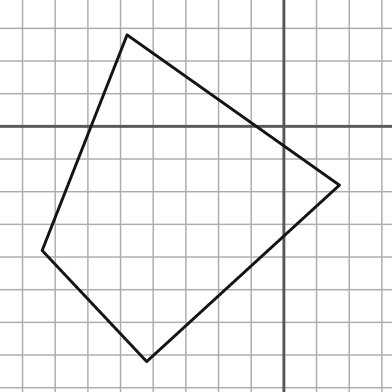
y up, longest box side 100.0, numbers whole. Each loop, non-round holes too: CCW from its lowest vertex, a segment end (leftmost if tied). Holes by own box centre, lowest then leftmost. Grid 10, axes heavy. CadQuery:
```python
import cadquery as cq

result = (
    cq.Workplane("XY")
    .moveTo(-42.0, -72.0)
    .lineTo(17.0, -18.0)
    .lineTo(-48.0, 28.0)
    .lineTo(-74.0, -38.0)
    .close()
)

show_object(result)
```